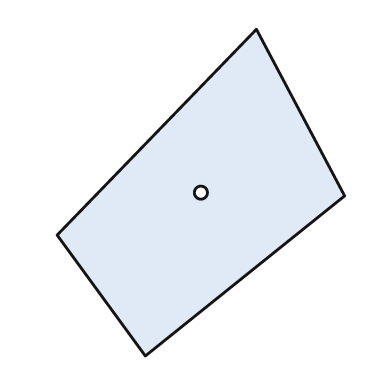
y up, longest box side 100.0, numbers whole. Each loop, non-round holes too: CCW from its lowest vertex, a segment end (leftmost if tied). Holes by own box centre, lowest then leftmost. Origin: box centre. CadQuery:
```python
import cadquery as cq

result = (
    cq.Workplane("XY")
    .moveTo(-17.0, -50.0)
    .lineTo(44.0, -1.0)
    .lineTo(17.0, 50.0)
    .lineTo(-44.0, -13.0)
    .close()
    .moveTo(0.0, 0.0)
    .circle(2.0)
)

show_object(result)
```